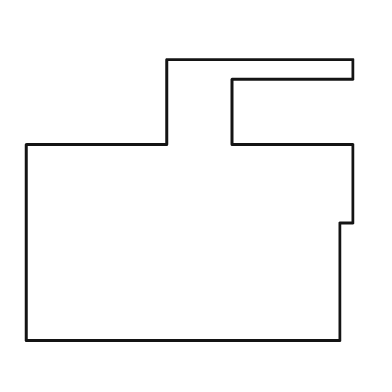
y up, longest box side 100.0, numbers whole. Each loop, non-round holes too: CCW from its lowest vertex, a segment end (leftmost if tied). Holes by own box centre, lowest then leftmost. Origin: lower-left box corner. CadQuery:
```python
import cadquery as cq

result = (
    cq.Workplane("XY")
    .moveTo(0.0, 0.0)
    .lineTo(96.0, 0.0)
    .lineTo(96.0, 36.0)
    .lineTo(100.0, 36.0)
    .lineTo(100.0, 60.0)
    .lineTo(63.0, 60.0)
    .lineTo(63.0, 80.0)
    .lineTo(100.0, 80.0)
    .lineTo(100.0, 86.0)
    .lineTo(43.0, 86.0)
    .lineTo(43.0, 60.0)
    .lineTo(0.0, 60.0)
    .close()
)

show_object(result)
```